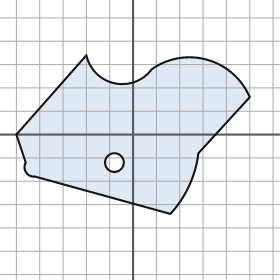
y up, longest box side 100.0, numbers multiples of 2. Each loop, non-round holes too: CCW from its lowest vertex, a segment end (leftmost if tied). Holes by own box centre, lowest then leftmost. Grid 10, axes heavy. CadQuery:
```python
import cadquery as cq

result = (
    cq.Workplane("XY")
    .moveTo(16.0, -34.0)
    .threePointArc((24.0, -22.0), (28.0, -8.0))
    .lineTo(50.0, 16.0)
    .threePointArc((32.0, 32.0), (8.0, 28.0))
    .threePointArc((-8.0, 22.0), (-20.0, 34.0))
    .lineTo(-50.0, 0.0)
    .lineTo(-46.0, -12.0)
    .threePointArc((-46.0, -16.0), (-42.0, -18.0))
    .close()
    .moveTo(-8.0, -12.0)
    .circle(4.0)
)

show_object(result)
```